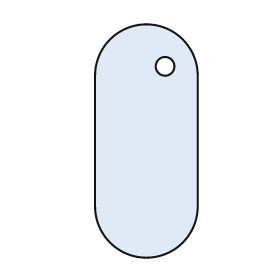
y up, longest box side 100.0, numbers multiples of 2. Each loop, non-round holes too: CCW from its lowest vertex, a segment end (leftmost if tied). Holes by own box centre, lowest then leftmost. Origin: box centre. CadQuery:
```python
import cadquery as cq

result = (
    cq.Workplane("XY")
    .moveTo(-22.0, -28.0)
    .threePointArc((0.0, -50.0), (22.0, -28.0))
    .lineTo(22.0, 28.0)
    .threePointArc((0.0, 50.0), (-22.0, 28.0))
    .close()
    .moveTo(8.0, 32.0)
    .circle(4.0)
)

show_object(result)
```